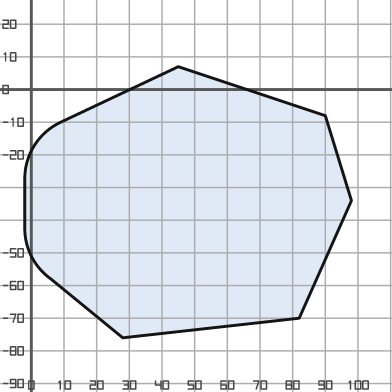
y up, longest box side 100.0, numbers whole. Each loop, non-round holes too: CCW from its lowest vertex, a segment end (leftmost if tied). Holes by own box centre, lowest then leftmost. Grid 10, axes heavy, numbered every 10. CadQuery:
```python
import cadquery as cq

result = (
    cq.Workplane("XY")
    .moveTo(28.0, -76.0)
    .lineTo(82.0, -70.0)
    .lineTo(98.0, -34.0)
    .lineTo(90.0, -8.0)
    .lineTo(45.0, 7.0)
    .lineTo(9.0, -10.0)
    .threePointArc((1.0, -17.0), (-2.0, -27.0))
    .lineTo(-2.0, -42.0)
    .threePointArc((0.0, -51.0), (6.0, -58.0))
    .close()
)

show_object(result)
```